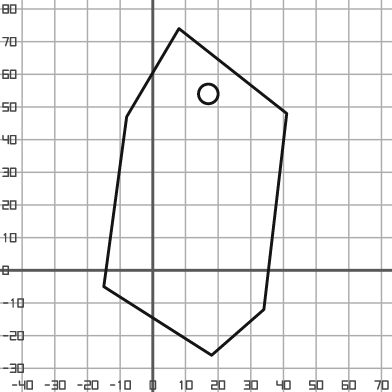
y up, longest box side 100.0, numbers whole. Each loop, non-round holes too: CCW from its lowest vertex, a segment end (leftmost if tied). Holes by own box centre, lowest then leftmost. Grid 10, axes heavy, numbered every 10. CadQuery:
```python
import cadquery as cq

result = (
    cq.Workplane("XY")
    .moveTo(18.0, -26.0)
    .lineTo(34.0, -12.0)
    .lineTo(41.0, 48.0)
    .lineTo(8.0, 74.0)
    .lineTo(-8.0, 47.0)
    .lineTo(-15.0, -5.0)
    .close()
    .moveTo(17.0, 54.0)
    .circle(3.0)
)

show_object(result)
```